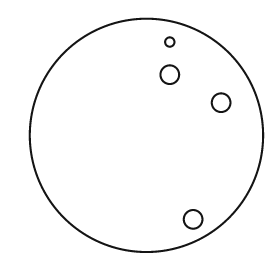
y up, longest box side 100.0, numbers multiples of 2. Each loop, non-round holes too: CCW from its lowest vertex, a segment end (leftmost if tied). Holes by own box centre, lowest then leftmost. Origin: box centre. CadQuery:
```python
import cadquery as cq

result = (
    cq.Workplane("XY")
    .moveTo(0.0, 0.0)
    .circle(50.0)
    .moveTo(20.0, -36.0)
    .circle(4.0)
    .moveTo(32.0, 14.0)
    .circle(4.0)
    .moveTo(10.0, 26.0)
    .circle(4.0)
    .moveTo(10.0, 40.0)
    .circle(2.0)
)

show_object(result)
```